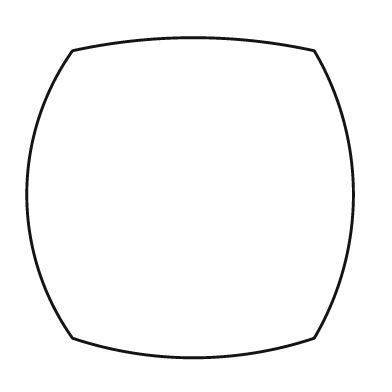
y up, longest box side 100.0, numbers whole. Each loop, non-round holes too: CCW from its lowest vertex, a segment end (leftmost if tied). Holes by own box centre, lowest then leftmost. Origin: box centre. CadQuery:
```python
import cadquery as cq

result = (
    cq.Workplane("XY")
    .moveTo(-36.0, -43.0)
    .threePointArc((1.0, -49.0), (38.0, -43.0))
    .threePointArc((50.0, 1.0), (38.0, 45.0))
    .threePointArc((1.0, 49.0), (-36.0, 45.0))
    .threePointArc((-50.0, 1.0), (-36.0, -43.0))
    .close()
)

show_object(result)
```